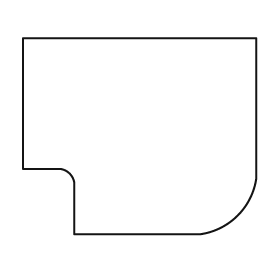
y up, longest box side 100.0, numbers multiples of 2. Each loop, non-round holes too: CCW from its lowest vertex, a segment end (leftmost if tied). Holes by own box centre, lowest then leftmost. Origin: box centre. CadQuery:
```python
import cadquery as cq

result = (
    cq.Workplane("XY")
    .moveTo(-28.0, -42.0)
    .lineTo(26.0, -42.0)
    .threePointArc((42.0, -34.0), (50.0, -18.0))
    .lineTo(50.0, 42.0)
    .lineTo(-50.0, 42.0)
    .lineTo(-50.0, -14.0)
    .lineTo(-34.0, -14.0)
    .threePointArc((-30.0, -16.0), (-28.0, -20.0))
    .close()
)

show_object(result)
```